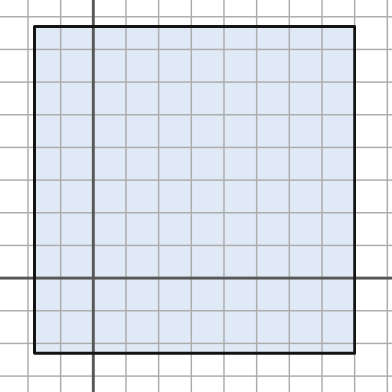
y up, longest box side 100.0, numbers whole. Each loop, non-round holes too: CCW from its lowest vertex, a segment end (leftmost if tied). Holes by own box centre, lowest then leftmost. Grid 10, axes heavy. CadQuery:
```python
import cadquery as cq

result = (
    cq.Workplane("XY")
    .moveTo(-18.0, -23.0)
    .lineTo(80.0, -23.0)
    .lineTo(80.0, 77.0)
    .lineTo(-18.0, 77.0)
    .close()
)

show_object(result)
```